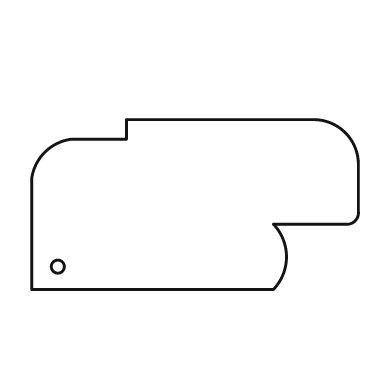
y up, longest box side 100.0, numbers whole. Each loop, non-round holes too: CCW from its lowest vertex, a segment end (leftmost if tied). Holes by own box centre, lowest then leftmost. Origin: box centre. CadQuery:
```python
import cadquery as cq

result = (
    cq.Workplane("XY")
    .moveTo(-50.0, -26.0)
    .lineTo(24.0, -26.0)
    .threePointArc((28.0, -16.0), (24.0, -6.0))
    .lineTo(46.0, -6.0)
    .threePointArc((49.0, -5.0), (50.0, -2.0))
    .lineTo(50.0, 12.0)
    .threePointArc((46.0, 22.0), (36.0, 26.0))
    .lineTo(-21.0, 26.0)
    .lineTo(-21.0, 20.0)
    .lineTo(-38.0, 20.0)
    .threePointArc((-46.0, 16.0), (-50.0, 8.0))
    .close()
    .moveTo(-42.0, -19.0)
    .circle(2.0)
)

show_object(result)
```